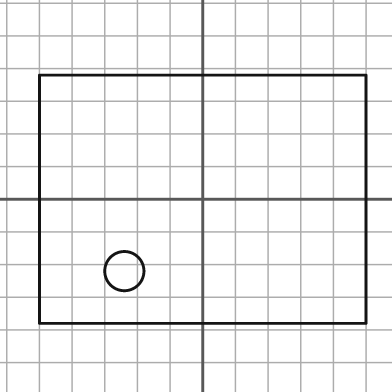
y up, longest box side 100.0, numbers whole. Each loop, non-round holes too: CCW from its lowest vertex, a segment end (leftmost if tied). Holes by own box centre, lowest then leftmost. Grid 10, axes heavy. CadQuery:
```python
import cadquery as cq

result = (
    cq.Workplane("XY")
    .moveTo(-50.0, -38.0)
    .lineTo(50.0, -38.0)
    .lineTo(50.0, 38.0)
    .lineTo(-50.0, 38.0)
    .close()
    .moveTo(-24.0, -22.0)
    .circle(6.0)
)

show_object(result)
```